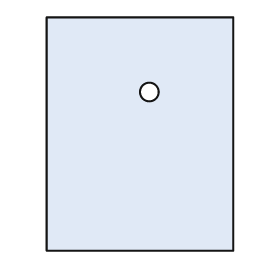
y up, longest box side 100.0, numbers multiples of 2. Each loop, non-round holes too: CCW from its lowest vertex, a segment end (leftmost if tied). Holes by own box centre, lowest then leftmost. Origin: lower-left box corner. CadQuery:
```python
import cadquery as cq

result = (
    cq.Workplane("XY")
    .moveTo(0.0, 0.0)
    .lineTo(80.0, 0.0)
    .lineTo(80.0, 100.0)
    .lineTo(0.0, 100.0)
    .close()
    .moveTo(44.0, 68.0)
    .circle(4.0)
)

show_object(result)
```